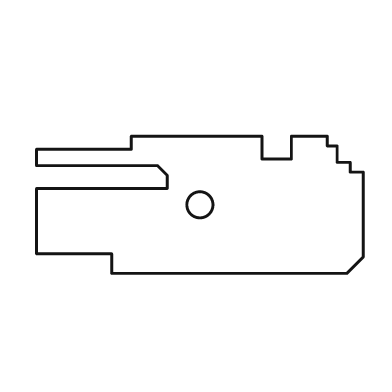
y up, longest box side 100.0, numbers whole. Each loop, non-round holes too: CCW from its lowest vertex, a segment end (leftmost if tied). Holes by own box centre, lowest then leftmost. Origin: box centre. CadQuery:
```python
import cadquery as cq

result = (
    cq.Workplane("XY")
    .moveTo(-27.0, -21.0)
    .lineTo(45.0, -21.0)
    .lineTo(50.0, -16.0)
    .lineTo(50.0, 10.0)
    .lineTo(46.0, 10.0)
    .lineTo(46.0, 13.0)
    .lineTo(42.0, 13.0)
    .lineTo(42.0, 18.0)
    .lineTo(39.0, 18.0)
    .lineTo(39.0, 21.0)
    .lineTo(28.0, 21.0)
    .lineTo(28.0, 14.0)
    .lineTo(19.0, 14.0)
    .lineTo(19.0, 21.0)
    .lineTo(-21.0, 21.0)
    .lineTo(-21.0, 17.0)
    .lineTo(-50.0, 17.0)
    .lineTo(-50.0, 12.0)
    .lineTo(-13.0, 12.0)
    .lineTo(-10.0, 9.0)
    .lineTo(-10.0, 5.0)
    .lineTo(-50.0, 5.0)
    .lineTo(-50.0, -15.0)
    .lineTo(-27.0, -15.0)
    .close()
    .moveTo(0.0, 0.0)
    .circle(4.0)
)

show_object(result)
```